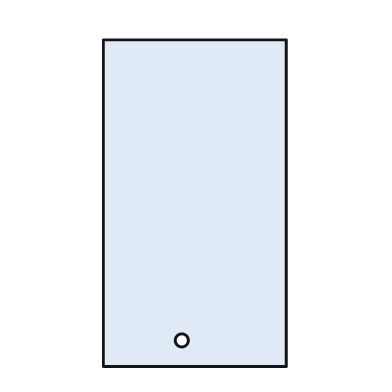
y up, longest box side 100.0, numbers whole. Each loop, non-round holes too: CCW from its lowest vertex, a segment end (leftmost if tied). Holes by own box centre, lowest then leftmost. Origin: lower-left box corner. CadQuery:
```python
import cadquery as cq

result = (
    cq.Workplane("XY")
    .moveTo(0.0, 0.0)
    .lineTo(56.0, 0.0)
    .lineTo(56.0, 100.0)
    .lineTo(0.0, 100.0)
    .close()
    .moveTo(24.0, 8.0)
    .circle(2.0)
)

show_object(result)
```